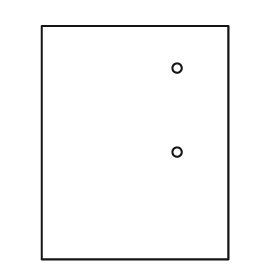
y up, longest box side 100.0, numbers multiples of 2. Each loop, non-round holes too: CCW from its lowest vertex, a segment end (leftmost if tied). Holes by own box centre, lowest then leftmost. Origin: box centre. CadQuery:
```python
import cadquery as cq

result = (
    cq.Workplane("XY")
    .moveTo(-40.0, -50.0)
    .lineTo(40.0, -50.0)
    .lineTo(40.0, 50.0)
    .lineTo(-40.0, 50.0)
    .close()
    .moveTo(18.0, -4.0)
    .circle(2.0)
    .moveTo(18.0, 32.0)
    .circle(2.0)
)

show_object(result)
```